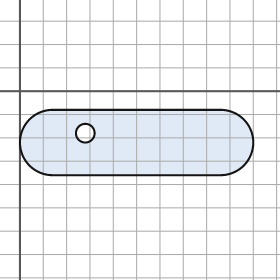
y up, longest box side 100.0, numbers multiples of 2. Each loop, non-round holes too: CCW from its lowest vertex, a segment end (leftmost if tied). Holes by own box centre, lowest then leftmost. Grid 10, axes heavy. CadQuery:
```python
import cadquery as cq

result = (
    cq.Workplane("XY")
    .moveTo(14.0, -36.0)
    .lineTo(86.0, -36.0)
    .threePointArc((100.0, -22.0), (86.0, -8.0))
    .lineTo(14.0, -8.0)
    .threePointArc((0.0, -22.0), (14.0, -36.0))
    .close()
    .moveTo(28.0, -18.0)
    .circle(4.0)
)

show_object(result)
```